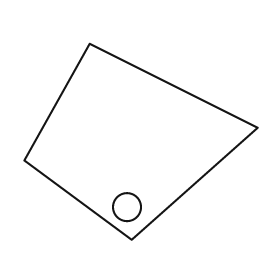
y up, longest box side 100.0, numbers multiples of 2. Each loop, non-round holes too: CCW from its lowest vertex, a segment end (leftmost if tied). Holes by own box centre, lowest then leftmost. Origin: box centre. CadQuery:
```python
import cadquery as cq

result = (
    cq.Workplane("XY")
    .moveTo(-4.0, -42.0)
    .lineTo(50.0, 6.0)
    .lineTo(-22.0, 42.0)
    .lineTo(-50.0, -8.0)
    .close()
    .moveTo(-6.0, -28.0)
    .circle(6.0)
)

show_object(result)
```